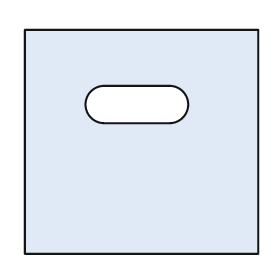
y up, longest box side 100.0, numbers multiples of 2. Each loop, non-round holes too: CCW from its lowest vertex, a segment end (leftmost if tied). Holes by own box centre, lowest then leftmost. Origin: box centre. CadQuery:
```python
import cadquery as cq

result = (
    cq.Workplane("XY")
    .moveTo(-50.0, -48.0)
    .lineTo(50.0, -48.0)
    .lineTo(50.0, 48.0)
    .lineTo(-50.0, 48.0)
    .close()
    .moveTo(-16.0, 8.0)
    .lineTo(12.0, 8.0)
    .threePointArc((20.0, 16.0), (12.0, 24.0))
    .lineTo(-16.0, 24.0)
    .threePointArc((-24.0, 16.0), (-16.0, 8.0))
    .close()
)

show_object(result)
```